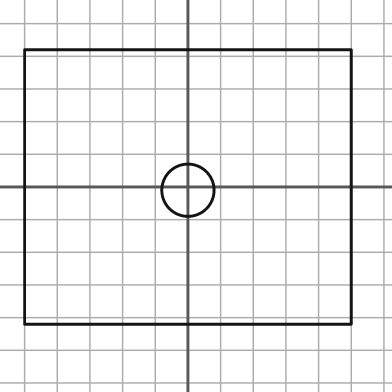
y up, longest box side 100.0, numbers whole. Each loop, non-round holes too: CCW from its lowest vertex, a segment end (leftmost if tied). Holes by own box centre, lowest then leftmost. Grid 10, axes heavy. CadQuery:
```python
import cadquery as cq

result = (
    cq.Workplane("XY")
    .moveTo(-50.0, -42.0)
    .lineTo(50.0, -42.0)
    .lineTo(50.0, 42.0)
    .lineTo(-50.0, 42.0)
    .close()
    .moveTo(0.0, -1.0)
    .circle(8.0)
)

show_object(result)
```